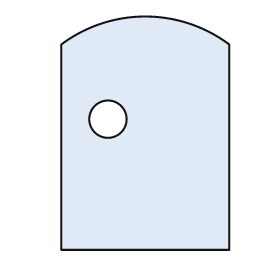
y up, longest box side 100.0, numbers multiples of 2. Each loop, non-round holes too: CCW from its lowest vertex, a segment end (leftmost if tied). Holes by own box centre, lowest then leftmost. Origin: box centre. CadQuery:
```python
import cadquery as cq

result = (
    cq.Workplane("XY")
    .moveTo(-36.0, -50.0)
    .lineTo(36.0, -50.0)
    .lineTo(36.0, 38.0)
    .threePointArc((0.0, 50.0), (-36.0, 38.0))
    .close()
    .moveTo(-16.0, 6.0)
    .circle(8.0)
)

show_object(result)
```